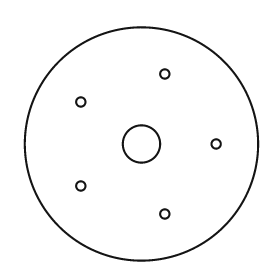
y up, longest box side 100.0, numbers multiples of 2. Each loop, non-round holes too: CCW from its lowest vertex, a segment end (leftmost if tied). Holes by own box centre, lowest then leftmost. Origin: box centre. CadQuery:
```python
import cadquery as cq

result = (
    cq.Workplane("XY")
    .moveTo(0.0, 0.0)
    .circle(50.0)
    .moveTo(10.0, -30.0)
    .circle(2.0)
    .moveTo(-26.0, -18.0)
    .circle(2.0)
    .moveTo(0.0, 0.0)
    .circle(8.0)
    .moveTo(32.0, 0.0)
    .circle(2.0)
    .moveTo(-26.0, 18.0)
    .circle(2.0)
    .moveTo(10.0, 30.0)
    .circle(2.0)
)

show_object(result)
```